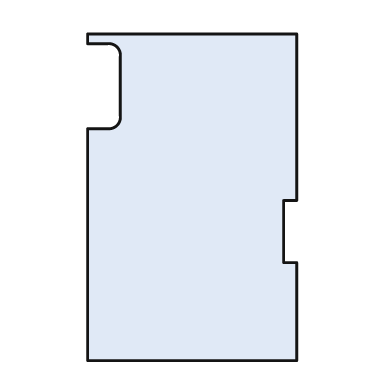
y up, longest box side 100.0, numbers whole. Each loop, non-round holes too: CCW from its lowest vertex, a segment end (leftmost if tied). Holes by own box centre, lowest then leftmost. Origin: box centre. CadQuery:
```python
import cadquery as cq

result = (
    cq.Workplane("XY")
    .moveTo(-32.0, -50.0)
    .lineTo(32.0, -50.0)
    .lineTo(32.0, -20.0)
    .lineTo(28.0, -20.0)
    .lineTo(28.0, -1.0)
    .lineTo(32.0, -1.0)
    .lineTo(32.0, 50.0)
    .lineTo(-32.0, 50.0)
    .lineTo(-32.0, 47.0)
    .lineTo(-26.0, 47.0)
    .threePointArc((-23.0, 46.0), (-22.0, 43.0))
    .lineTo(-22.0, 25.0)
    .threePointArc((-23.0, 22.0), (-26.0, 21.0))
    .lineTo(-32.0, 21.0)
    .close()
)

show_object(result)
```